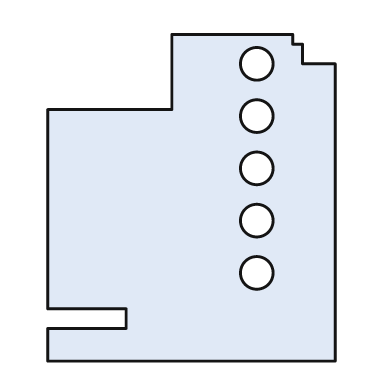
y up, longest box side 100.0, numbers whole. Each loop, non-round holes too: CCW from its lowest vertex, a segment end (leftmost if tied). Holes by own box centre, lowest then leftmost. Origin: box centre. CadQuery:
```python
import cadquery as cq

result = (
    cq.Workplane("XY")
    .moveTo(-44.0, -50.0)
    .lineTo(44.0, -50.0)
    .lineTo(44.0, 41.0)
    .lineTo(34.0, 41.0)
    .lineTo(34.0, 47.0)
    .lineTo(31.0, 47.0)
    .lineTo(31.0, 50.0)
    .lineTo(-6.0, 50.0)
    .lineTo(-6.0, 27.0)
    .lineTo(-44.0, 27.0)
    .lineTo(-44.0, -34.0)
    .lineTo(-20.0, -34.0)
    .lineTo(-20.0, -40.0)
    .lineTo(-44.0, -40.0)
    .close()
    .moveTo(20.0, -23.0)
    .circle(5.0)
    .moveTo(20.0, -7.0)
    .circle(5.0)
    .moveTo(20.0, 9.0)
    .circle(5.0)
    .moveTo(20.0, 25.0)
    .circle(5.0)
    .moveTo(20.0, 41.0)
    .circle(5.0)
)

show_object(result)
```